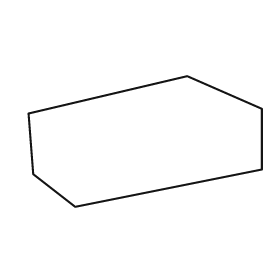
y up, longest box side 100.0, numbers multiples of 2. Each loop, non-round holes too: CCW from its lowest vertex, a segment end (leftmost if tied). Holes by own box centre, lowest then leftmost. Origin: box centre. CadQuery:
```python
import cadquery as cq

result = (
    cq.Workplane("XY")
    .moveTo(-30.0, -28.0)
    .lineTo(50.0, -12.0)
    .lineTo(50.0, 14.0)
    .lineTo(18.0, 28.0)
    .lineTo(-50.0, 12.0)
    .lineTo(-48.0, -14.0)
    .close()
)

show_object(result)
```